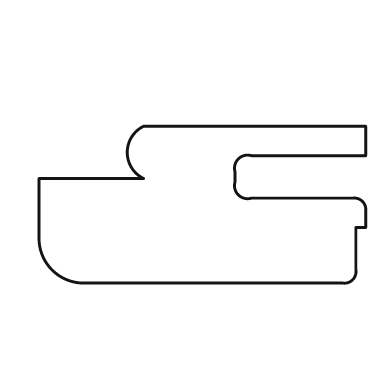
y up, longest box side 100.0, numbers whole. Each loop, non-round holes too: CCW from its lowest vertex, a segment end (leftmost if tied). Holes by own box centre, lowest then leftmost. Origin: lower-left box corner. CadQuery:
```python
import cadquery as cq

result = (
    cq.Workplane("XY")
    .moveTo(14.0, 0.0)
    .lineTo(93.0, 0.0)
    .threePointArc((96.0, 1.0), (97.0, 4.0))
    .lineTo(97.0, 17.0)
    .lineTo(100.0, 17.0)
    .lineTo(100.0, 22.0)
    .threePointArc((99.0, 25.0), (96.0, 26.0))
    .lineTo(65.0, 26.0)
    .threePointArc((61.0, 27.0), (60.0, 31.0))
    .lineTo(60.0, 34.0)
    .threePointArc((61.0, 38.0), (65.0, 39.0))
    .lineTo(100.0, 39.0)
    .lineTo(100.0, 48.0)
    .lineTo(32.0, 48.0)
    .threePointArc((27.0, 40.0), (32.0, 32.0))
    .lineTo(0.0, 32.0)
    .lineTo(0.0, 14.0)
    .threePointArc((4.0, 4.0), (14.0, 0.0))
    .close()
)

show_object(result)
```